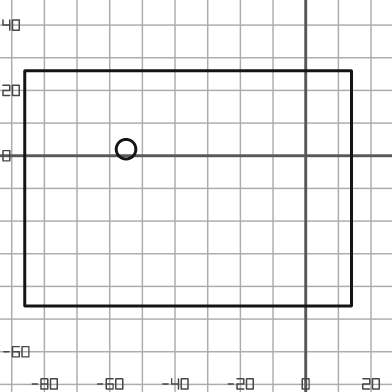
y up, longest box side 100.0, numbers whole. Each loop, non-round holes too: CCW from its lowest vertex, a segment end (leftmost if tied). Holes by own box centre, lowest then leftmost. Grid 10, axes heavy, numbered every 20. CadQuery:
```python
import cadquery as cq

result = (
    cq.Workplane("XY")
    .moveTo(-86.0, -46.0)
    .lineTo(14.0, -46.0)
    .lineTo(14.0, 26.0)
    .lineTo(-86.0, 26.0)
    .close()
    .moveTo(-55.0, 2.0)
    .circle(3.0)
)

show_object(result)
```